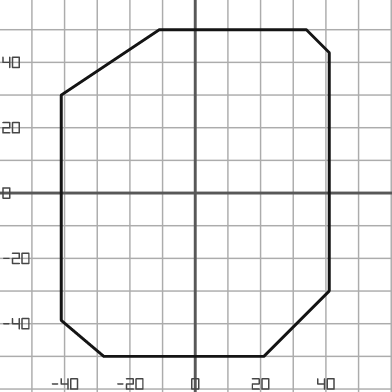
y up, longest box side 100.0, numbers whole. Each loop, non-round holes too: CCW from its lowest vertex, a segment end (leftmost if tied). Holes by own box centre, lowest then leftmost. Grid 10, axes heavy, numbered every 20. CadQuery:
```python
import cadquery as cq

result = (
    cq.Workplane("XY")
    .moveTo(-28.0, -50.0)
    .lineTo(21.0, -50.0)
    .lineTo(41.0, -30.0)
    .lineTo(41.0, 43.0)
    .lineTo(34.0, 50.0)
    .lineTo(-11.0, 50.0)
    .lineTo(-41.0, 30.0)
    .lineTo(-41.0, -39.0)
    .close()
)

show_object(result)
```